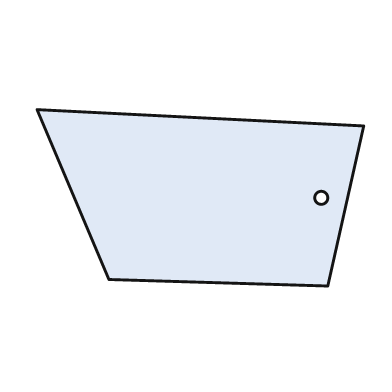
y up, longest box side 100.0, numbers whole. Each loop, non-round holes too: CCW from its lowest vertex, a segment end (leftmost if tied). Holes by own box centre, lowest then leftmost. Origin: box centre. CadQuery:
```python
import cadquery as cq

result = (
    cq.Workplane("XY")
    .moveTo(39.0, -27.0)
    .lineTo(50.0, 22.0)
    .lineTo(-50.0, 27.0)
    .lineTo(-28.0, -25.0)
    .close()
    .moveTo(37.0, 0.0)
    .circle(2.0)
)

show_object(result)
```